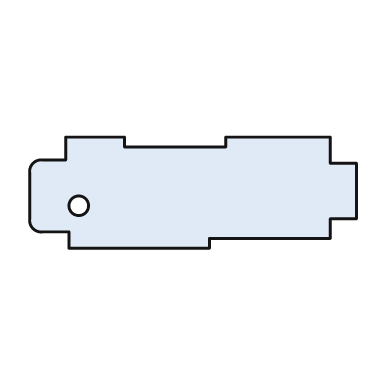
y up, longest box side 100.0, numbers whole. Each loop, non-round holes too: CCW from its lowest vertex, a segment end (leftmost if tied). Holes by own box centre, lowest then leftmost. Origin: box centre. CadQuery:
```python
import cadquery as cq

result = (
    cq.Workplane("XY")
    .moveTo(-38.0, -17.0)
    .lineTo(5.0, -17.0)
    .lineTo(5.0, -14.0)
    .lineTo(42.0, -14.0)
    .lineTo(42.0, -8.0)
    .lineTo(50.0, -8.0)
    .lineTo(50.0, 9.0)
    .lineTo(42.0, 9.0)
    .lineTo(42.0, 17.0)
    .lineTo(10.0, 17.0)
    .lineTo(10.0, 14.0)
    .lineTo(-21.0, 14.0)
    .lineTo(-21.0, 17.0)
    .lineTo(-39.0, 17.0)
    .lineTo(-39.0, 10.0)
    .lineTo(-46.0, 10.0)
    .threePointArc((-49.0, 9.0), (-50.0, 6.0))
    .lineTo(-50.0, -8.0)
    .threePointArc((-49.0, -11.0), (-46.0, -12.0))
    .lineTo(-38.0, -12.0)
    .close()
    .moveTo(-35.0, -4.0)
    .circle(3.0)
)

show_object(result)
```